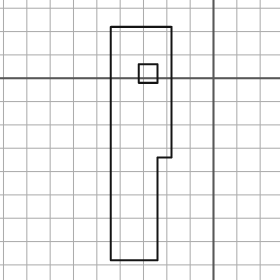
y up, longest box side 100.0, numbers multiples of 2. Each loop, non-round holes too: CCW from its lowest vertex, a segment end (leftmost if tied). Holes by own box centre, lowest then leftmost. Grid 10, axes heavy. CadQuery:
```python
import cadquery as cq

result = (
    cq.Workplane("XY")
    .moveTo(-44.0, -78.0)
    .lineTo(-24.0, -78.0)
    .lineTo(-24.0, -34.0)
    .lineTo(-18.0, -34.0)
    .lineTo(-18.0, 22.0)
    .lineTo(-44.0, 22.0)
    .close()
    .moveTo(-32.0, -2.0)
    .lineTo(-24.0, -2.0)
    .lineTo(-24.0, 6.0)
    .lineTo(-32.0, 6.0)
    .close()
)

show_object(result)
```